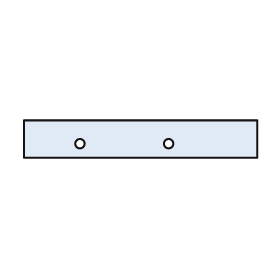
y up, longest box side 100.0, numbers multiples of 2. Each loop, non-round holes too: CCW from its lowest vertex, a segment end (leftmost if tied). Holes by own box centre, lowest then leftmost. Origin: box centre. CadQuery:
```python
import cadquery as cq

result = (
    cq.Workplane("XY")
    .moveTo(-50.0, -8.0)
    .lineTo(50.0, -8.0)
    .lineTo(50.0, 8.0)
    .lineTo(-50.0, 8.0)
    .close()
    .moveTo(-26.0, -2.0)
    .circle(2.0)
    .moveTo(12.0, -2.0)
    .circle(2.0)
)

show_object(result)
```